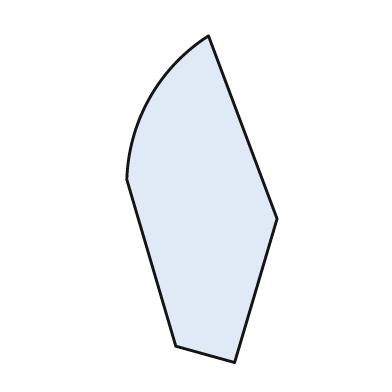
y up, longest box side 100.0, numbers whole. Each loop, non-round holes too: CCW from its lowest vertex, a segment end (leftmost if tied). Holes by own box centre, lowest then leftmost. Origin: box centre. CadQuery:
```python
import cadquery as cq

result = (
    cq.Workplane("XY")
    .moveTo(10.0, -50.0)
    .lineTo(23.0, -6.0)
    .lineTo(2.0, 50.0)
    .threePointArc((-16.0, 31.0), (-23.0, 6.0))
    .lineTo(-8.0, -45.0)
    .close()
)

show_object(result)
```